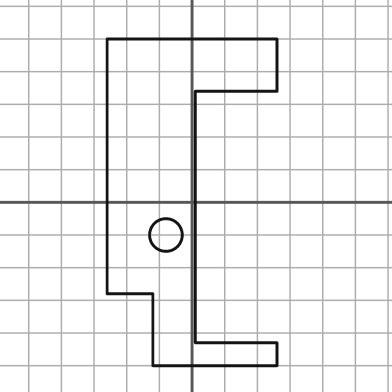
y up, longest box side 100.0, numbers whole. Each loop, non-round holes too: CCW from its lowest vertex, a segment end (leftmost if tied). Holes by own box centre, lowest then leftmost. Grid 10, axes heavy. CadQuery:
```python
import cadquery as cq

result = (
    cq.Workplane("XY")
    .moveTo(-12.0, -50.0)
    .lineTo(26.0, -50.0)
    .lineTo(26.0, -43.0)
    .lineTo(1.0, -43.0)
    .lineTo(1.0, 34.0)
    .lineTo(26.0, 34.0)
    .lineTo(26.0, 50.0)
    .lineTo(-26.0, 50.0)
    .lineTo(-26.0, -28.0)
    .lineTo(-12.0, -28.0)
    .close()
    .moveTo(-8.0, -10.0)
    .circle(5.0)
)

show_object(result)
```